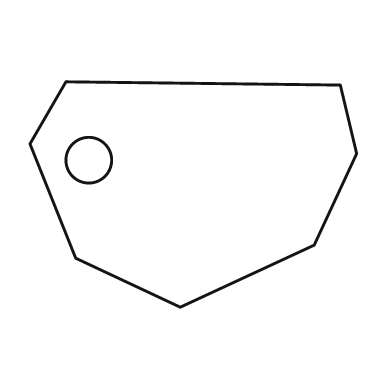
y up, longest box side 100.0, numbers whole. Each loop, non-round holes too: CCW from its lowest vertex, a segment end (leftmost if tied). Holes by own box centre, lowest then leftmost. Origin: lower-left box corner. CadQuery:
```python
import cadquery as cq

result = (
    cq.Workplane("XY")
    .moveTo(46.0, 0.0)
    .lineTo(87.0, 19.0)
    .lineTo(100.0, 47.0)
    .lineTo(95.0, 68.0)
    .lineTo(11.0, 69.0)
    .lineTo(0.0, 50.0)
    .lineTo(14.0, 15.0)
    .close()
    .moveTo(18.0, 45.0)
    .circle(7.0)
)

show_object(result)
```